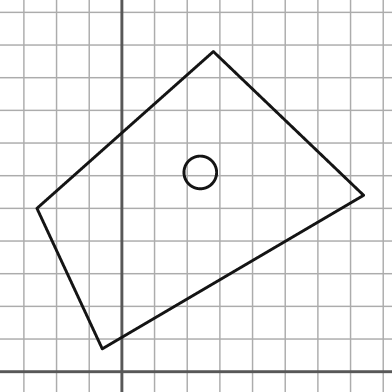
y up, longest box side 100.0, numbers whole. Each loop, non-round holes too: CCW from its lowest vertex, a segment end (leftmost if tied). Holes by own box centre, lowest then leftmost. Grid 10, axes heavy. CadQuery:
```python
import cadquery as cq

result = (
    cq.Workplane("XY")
    .moveTo(-6.0, 7.0)
    .lineTo(74.0, 54.0)
    .lineTo(28.0, 98.0)
    .lineTo(-26.0, 50.0)
    .close()
    .moveTo(24.0, 61.0)
    .circle(5.0)
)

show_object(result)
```